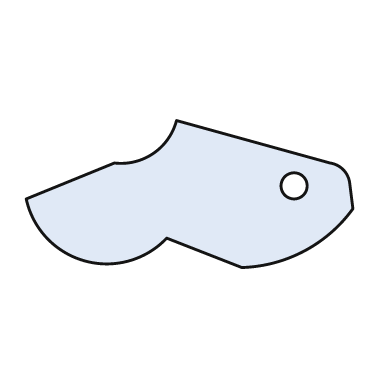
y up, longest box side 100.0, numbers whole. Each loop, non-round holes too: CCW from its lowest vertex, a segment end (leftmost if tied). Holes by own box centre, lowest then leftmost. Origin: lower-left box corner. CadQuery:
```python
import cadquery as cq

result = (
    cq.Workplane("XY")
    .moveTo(66.0, 0.0)
    .threePointArc((85.0, 5.0), (100.0, 18.0))
    .lineTo(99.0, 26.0)
    .threePointArc((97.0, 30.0), (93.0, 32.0))
    .lineTo(46.0, 45.0)
    .threePointArc((39.0, 35.0), (27.0, 32.0))
    .lineTo(0.0, 21.0)
    .threePointArc((18.0, 2.0), (43.0, 9.0))
    .close()
    .moveTo(82.0, 25.0)
    .circle(4.0)
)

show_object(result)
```